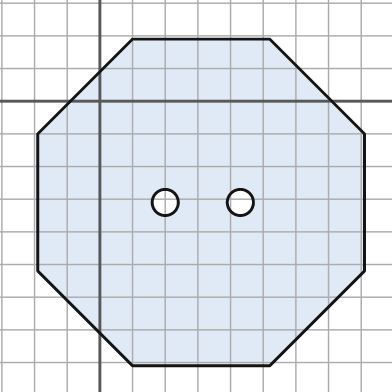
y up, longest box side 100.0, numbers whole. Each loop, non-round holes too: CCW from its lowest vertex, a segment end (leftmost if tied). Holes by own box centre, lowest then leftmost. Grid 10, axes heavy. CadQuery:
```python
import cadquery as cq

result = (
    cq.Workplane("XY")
    .moveTo(10.0, -81.0)
    .lineTo(52.0, -81.0)
    .lineTo(81.0, -52.0)
    .lineTo(81.0, -10.0)
    .lineTo(52.0, 19.0)
    .lineTo(10.0, 19.0)
    .lineTo(-19.0, -10.0)
    .lineTo(-19.0, -52.0)
    .close()
    .moveTo(20.0, -31.0)
    .circle(4.0)
    .moveTo(43.0, -31.0)
    .circle(4.0)
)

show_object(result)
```